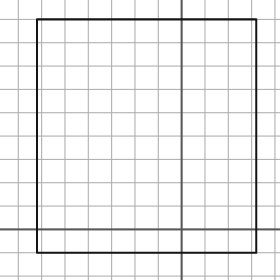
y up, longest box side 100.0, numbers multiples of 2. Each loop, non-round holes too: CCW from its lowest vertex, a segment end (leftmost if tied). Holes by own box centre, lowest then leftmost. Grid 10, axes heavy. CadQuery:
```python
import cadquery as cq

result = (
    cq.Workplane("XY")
    .moveTo(-62.0, -10.0)
    .lineTo(32.0, -10.0)
    .lineTo(32.0, 90.0)
    .lineTo(-62.0, 90.0)
    .close()
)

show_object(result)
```